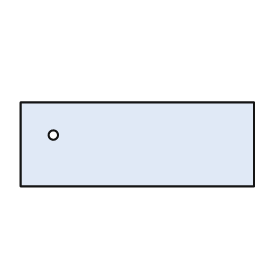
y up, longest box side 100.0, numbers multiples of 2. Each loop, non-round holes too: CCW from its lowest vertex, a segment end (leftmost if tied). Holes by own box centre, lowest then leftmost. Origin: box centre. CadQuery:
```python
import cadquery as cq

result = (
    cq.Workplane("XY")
    .moveTo(-50.0, -18.0)
    .lineTo(50.0, -18.0)
    .lineTo(50.0, 18.0)
    .lineTo(-50.0, 18.0)
    .close()
    .moveTo(-36.0, 4.0)
    .circle(2.0)
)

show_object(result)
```